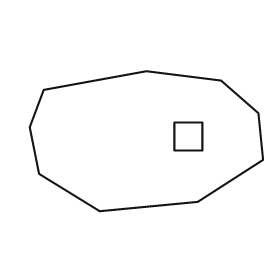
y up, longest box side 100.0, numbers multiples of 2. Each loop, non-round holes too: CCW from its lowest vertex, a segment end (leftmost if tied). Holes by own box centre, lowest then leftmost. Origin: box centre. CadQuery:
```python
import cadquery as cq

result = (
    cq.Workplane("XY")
    .moveTo(-20.0, -30.0)
    .lineTo(22.0, -26.0)
    .lineTo(50.0, -8.0)
    .lineTo(48.0, 12.0)
    .lineTo(32.0, 26.0)
    .lineTo(0.0, 30.0)
    .lineTo(-44.0, 22.0)
    .lineTo(-50.0, 6.0)
    .lineTo(-46.0, -14.0)
    .close()
    .moveTo(12.0, -4.0)
    .lineTo(24.0, -4.0)
    .lineTo(24.0, 8.0)
    .lineTo(12.0, 8.0)
    .close()
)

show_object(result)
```